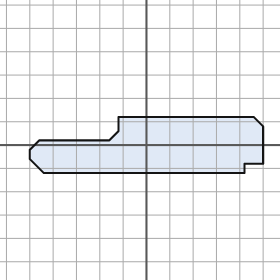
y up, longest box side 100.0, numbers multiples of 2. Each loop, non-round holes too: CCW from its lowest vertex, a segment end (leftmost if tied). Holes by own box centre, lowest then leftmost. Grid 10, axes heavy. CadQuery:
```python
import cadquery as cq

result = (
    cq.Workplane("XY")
    .moveTo(-44.0, -12.0)
    .lineTo(42.0, -12.0)
    .lineTo(42.0, -8.0)
    .lineTo(50.0, -8.0)
    .lineTo(50.0, 8.0)
    .lineTo(46.0, 12.0)
    .lineTo(-12.0, 12.0)
    .lineTo(-12.0, 6.0)
    .lineTo(-16.0, 2.0)
    .lineTo(-46.0, 2.0)
    .lineTo(-50.0, -2.0)
    .lineTo(-50.0, -6.0)
    .close()
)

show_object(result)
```